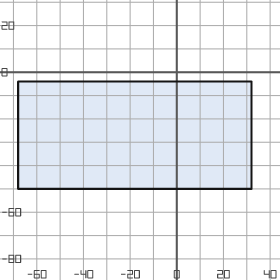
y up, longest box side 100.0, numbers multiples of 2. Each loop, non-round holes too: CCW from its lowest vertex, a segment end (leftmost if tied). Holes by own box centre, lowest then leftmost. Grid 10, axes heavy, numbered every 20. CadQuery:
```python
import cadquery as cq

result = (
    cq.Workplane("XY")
    .moveTo(-68.0, -50.0)
    .lineTo(32.0, -50.0)
    .lineTo(32.0, -4.0)
    .lineTo(-68.0, -4.0)
    .close()
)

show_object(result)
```